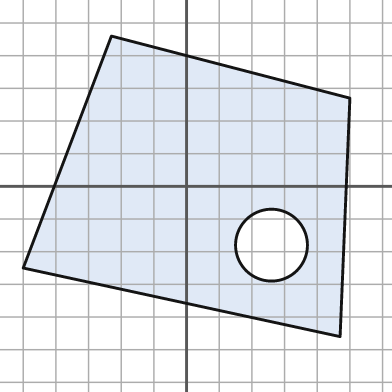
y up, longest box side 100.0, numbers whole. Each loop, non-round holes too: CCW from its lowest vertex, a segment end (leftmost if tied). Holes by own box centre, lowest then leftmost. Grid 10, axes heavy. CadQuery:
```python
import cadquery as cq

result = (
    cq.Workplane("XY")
    .moveTo(47.0, -46.0)
    .lineTo(50.0, 27.0)
    .lineTo(-23.0, 46.0)
    .lineTo(-50.0, -25.0)
    .close()
    .moveTo(26.0, -18.0)
    .circle(11.0)
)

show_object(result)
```